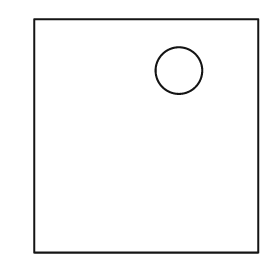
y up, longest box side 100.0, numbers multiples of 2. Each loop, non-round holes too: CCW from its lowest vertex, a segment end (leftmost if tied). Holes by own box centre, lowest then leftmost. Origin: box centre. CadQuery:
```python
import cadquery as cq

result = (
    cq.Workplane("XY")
    .moveTo(-48.0, -50.0)
    .lineTo(48.0, -50.0)
    .lineTo(48.0, 50.0)
    .lineTo(-48.0, 50.0)
    .close()
    .moveTo(14.0, 28.0)
    .circle(10.0)
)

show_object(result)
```